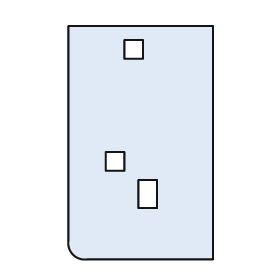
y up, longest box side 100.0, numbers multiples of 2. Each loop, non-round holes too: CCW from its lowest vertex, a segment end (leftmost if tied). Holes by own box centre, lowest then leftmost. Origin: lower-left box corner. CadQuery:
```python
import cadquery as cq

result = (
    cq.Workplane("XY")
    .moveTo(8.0, 0.0)
    .lineTo(62.0, 0.0)
    .lineTo(62.0, 100.0)
    .lineTo(0.0, 100.0)
    .lineTo(0.0, 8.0)
    .threePointArc((2.0, 2.0), (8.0, 0.0))
    .close()
    .moveTo(30.0, 22.0)
    .lineTo(38.0, 22.0)
    .lineTo(38.0, 34.0)
    .lineTo(30.0, 34.0)
    .close()
    .moveTo(16.0, 38.0)
    .lineTo(24.0, 38.0)
    .lineTo(24.0, 46.0)
    .lineTo(16.0, 46.0)
    .close()
    .moveTo(24.0, 86.0)
    .lineTo(32.0, 86.0)
    .lineTo(32.0, 94.0)
    .lineTo(24.0, 94.0)
    .close()
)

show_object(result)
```